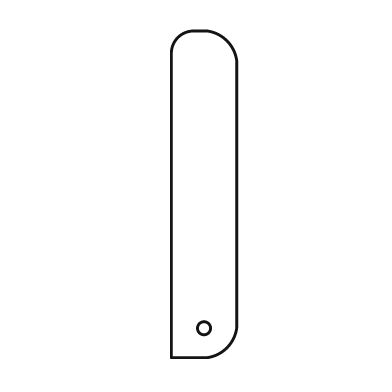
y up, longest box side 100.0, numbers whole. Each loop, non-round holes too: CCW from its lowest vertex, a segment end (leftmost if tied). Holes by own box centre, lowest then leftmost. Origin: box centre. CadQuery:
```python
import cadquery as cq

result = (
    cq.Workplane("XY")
    .moveTo(-10.0, -50.0)
    .lineTo(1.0, -50.0)
    .threePointArc((7.0, -47.0), (10.0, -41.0))
    .lineTo(10.0, 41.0)
    .threePointArc((7.0, 47.0), (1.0, 50.0))
    .lineTo(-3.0, 50.0)
    .threePointArc((-8.0, 48.0), (-10.0, 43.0))
    .close()
    .moveTo(0.0, -41.0)
    .circle(2.0)
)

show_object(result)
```